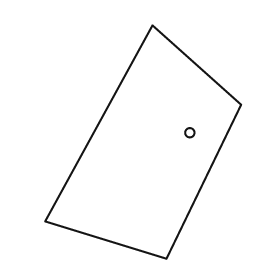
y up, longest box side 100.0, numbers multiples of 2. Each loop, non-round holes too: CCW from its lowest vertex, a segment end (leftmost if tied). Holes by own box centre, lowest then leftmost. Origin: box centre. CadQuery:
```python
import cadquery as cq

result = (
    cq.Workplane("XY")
    .moveTo(10.0, -50.0)
    .lineTo(42.0, 16.0)
    .lineTo(4.0, 50.0)
    .lineTo(-42.0, -34.0)
    .close()
    .moveTo(20.0, 4.0)
    .circle(2.0)
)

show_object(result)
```